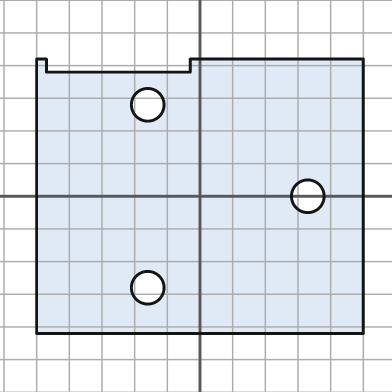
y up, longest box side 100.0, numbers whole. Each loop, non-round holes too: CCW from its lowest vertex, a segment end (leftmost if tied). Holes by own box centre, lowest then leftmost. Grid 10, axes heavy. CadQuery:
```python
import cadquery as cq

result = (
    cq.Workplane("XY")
    .moveTo(-50.0, -42.0)
    .lineTo(50.0, -42.0)
    .lineTo(50.0, 42.0)
    .lineTo(-3.0, 42.0)
    .lineTo(-3.0, 38.0)
    .lineTo(-47.0, 38.0)
    .lineTo(-47.0, 42.0)
    .lineTo(-50.0, 42.0)
    .close()
    .moveTo(-16.0, -28.0)
    .circle(5.0)
    .moveTo(33.0, 0.0)
    .circle(5.0)
    .moveTo(-16.0, 28.0)
    .circle(5.0)
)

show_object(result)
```